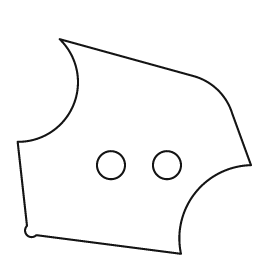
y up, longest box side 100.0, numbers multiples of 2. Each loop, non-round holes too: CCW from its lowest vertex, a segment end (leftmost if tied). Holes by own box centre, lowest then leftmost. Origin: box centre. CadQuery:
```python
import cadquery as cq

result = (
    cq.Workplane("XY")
    .moveTo(20.0, -46.0)
    .threePointArc((26.0, -20.0), (50.0, -8.0))
    .lineTo(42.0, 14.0)
    .threePointArc((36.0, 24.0), (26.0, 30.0))
    .lineTo(-32.0, 46.0)
    .threePointArc((-26.0, 18.0), (-50.0, 2.0))
    .lineTo(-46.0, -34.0)
    .threePointArc((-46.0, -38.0), (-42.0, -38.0))
    .close()
    .moveTo(-10.0, -8.0)
    .circle(6.0)
    .moveTo(14.0, -8.0)
    .circle(6.0)
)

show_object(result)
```